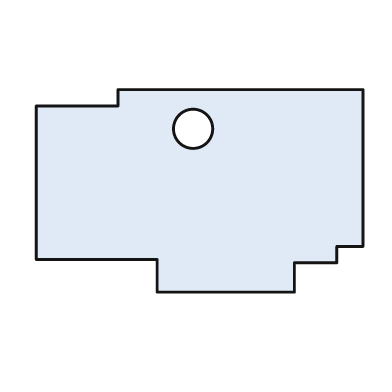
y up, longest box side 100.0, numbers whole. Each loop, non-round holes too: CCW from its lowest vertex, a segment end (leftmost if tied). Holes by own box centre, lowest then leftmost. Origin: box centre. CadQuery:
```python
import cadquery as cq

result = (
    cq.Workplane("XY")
    .moveTo(-13.0, -31.0)
    .lineTo(29.0, -31.0)
    .lineTo(29.0, -22.0)
    .lineTo(42.0, -22.0)
    .lineTo(42.0, -17.0)
    .lineTo(50.0, -17.0)
    .lineTo(50.0, 31.0)
    .lineTo(-25.0, 31.0)
    .lineTo(-25.0, 26.0)
    .lineTo(-50.0, 26.0)
    .lineTo(-50.0, -21.0)
    .lineTo(-13.0, -21.0)
    .close()
    .moveTo(-2.0, 19.0)
    .circle(6.0)
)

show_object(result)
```